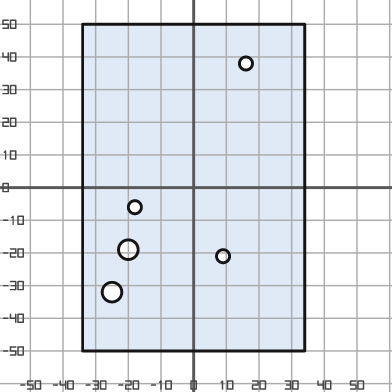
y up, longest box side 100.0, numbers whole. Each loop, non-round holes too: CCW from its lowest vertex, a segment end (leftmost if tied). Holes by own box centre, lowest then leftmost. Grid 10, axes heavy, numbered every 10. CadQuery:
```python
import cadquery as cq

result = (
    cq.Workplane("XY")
    .moveTo(-34.0, -50.0)
    .lineTo(34.0, -50.0)
    .lineTo(34.0, 50.0)
    .lineTo(-34.0, 50.0)
    .close()
    .moveTo(-25.0, -32.0)
    .circle(3.0)
    .moveTo(9.0, -21.0)
    .circle(2.0)
    .moveTo(-20.0, -19.0)
    .circle(3.0)
    .moveTo(-18.0, -6.0)
    .circle(2.0)
    .moveTo(16.0, 38.0)
    .circle(2.0)
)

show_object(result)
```